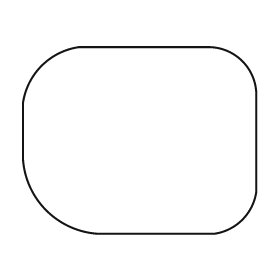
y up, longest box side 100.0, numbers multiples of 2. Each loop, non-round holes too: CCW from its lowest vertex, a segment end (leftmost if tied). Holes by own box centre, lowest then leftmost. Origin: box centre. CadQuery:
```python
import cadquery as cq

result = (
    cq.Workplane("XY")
    .moveTo(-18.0, -40.0)
    .lineTo(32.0, -40.0)
    .threePointArc((44.0, -34.0), (50.0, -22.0))
    .lineTo(50.0, 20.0)
    .threePointArc((44.0, 34.0), (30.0, 40.0))
    .lineTo(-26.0, 40.0)
    .threePointArc((-42.0, 32.0), (-50.0, 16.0))
    .lineTo(-50.0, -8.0)
    .threePointArc((-40.0, -30.0), (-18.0, -40.0))
    .close()
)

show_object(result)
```